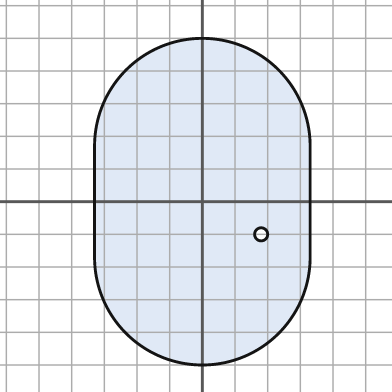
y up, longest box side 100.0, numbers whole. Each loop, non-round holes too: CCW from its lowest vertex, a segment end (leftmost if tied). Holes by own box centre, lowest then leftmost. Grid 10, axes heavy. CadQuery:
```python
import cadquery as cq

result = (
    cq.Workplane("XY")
    .moveTo(-33.0, -17.0)
    .threePointArc((0.0, -50.0), (33.0, -17.0))
    .lineTo(33.0, 17.0)
    .threePointArc((0.0, 50.0), (-33.0, 17.0))
    .close()
    .moveTo(18.0, -10.0)
    .circle(2.0)
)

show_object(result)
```